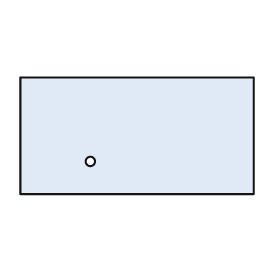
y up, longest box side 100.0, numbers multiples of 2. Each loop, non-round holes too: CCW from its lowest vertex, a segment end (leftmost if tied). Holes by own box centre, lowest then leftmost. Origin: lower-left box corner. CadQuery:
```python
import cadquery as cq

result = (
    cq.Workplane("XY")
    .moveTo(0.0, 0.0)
    .lineTo(100.0, 0.0)
    .lineTo(100.0, 50.0)
    .lineTo(0.0, 50.0)
    .close()
    .moveTo(30.0, 14.0)
    .circle(2.0)
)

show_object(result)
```